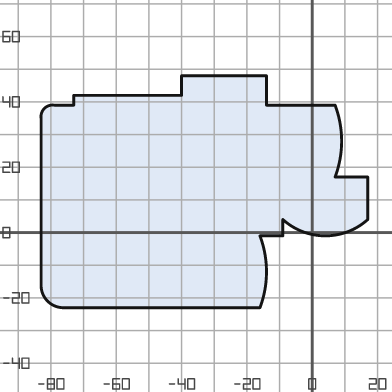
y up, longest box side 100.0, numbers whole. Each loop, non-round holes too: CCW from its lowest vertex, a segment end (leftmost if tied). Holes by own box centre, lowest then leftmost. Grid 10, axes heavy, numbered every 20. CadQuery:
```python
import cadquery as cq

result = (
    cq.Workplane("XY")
    .moveTo(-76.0, -23.0)
    .lineTo(-16.0, -23.0)
    .threePointArc((-14.0, -12.0), (-16.0, -1.0))
    .lineTo(-9.0, -1.0)
    .lineTo(-9.0, 4.0)
    .threePointArc((4.0, -1.0), (17.0, 4.0))
    .lineTo(17.0, 17.0)
    .lineTo(7.0, 17.0)
    .threePointArc((9.0, 28.0), (7.0, 39.0))
    .lineTo(-14.0, 39.0)
    .lineTo(-14.0, 48.0)
    .lineTo(-40.0, 48.0)
    .lineTo(-40.0, 42.0)
    .lineTo(-73.0, 42.0)
    .lineTo(-73.0, 39.0)
    .lineTo(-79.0, 39.0)
    .threePointArc((-82.0, 38.0), (-83.0, 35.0))
    .lineTo(-83.0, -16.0)
    .threePointArc((-81.0, -21.0), (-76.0, -23.0))
    .close()
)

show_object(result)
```